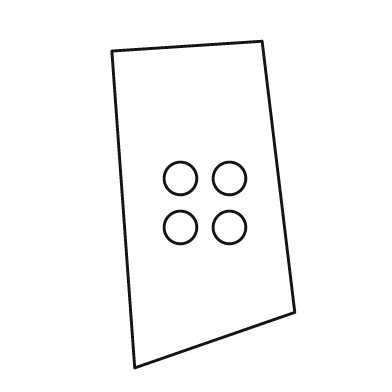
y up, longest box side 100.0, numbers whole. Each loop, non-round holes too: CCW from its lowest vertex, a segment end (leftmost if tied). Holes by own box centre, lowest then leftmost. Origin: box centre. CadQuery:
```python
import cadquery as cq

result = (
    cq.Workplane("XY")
    .moveTo(-21.0, -50.0)
    .lineTo(28.0, -33.0)
    .lineTo(18.0, 50.0)
    .lineTo(-28.0, 47.0)
    .close()
    .moveTo(-7.0, -7.0)
    .circle(5.0)
    .moveTo(8.0, -7.0)
    .circle(5.0)
    .moveTo(-7.0, 8.0)
    .circle(5.0)
    .moveTo(8.0, 8.0)
    .circle(5.0)
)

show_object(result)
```